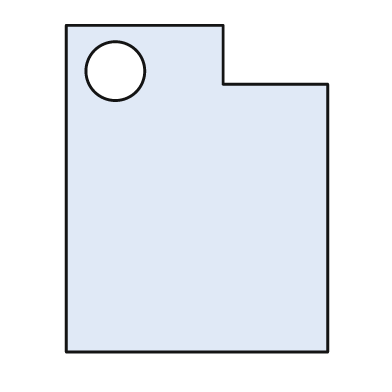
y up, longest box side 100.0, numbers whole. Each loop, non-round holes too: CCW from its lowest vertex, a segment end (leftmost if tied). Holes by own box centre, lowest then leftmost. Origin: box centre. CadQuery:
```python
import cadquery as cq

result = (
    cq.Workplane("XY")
    .moveTo(-40.0, -50.0)
    .lineTo(40.0, -50.0)
    .lineTo(40.0, 32.0)
    .lineTo(8.0, 32.0)
    .lineTo(8.0, 50.0)
    .lineTo(-40.0, 50.0)
    .close()
    .moveTo(-25.0, 36.0)
    .circle(9.0)
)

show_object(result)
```